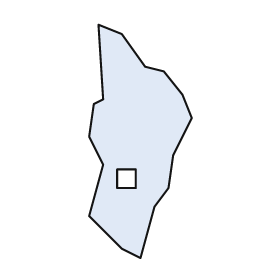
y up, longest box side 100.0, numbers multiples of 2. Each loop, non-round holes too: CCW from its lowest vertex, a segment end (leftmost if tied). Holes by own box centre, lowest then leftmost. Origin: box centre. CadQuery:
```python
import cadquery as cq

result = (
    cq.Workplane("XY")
    .moveTo(0.0, -50.0)
    .lineTo(6.0, -28.0)
    .lineTo(12.0, -20.0)
    .lineTo(14.0, -6.0)
    .lineTo(22.0, 10.0)
    .lineTo(18.0, 20.0)
    .lineTo(10.0, 30.0)
    .lineTo(2.0, 32.0)
    .lineTo(-8.0, 46.0)
    .lineTo(-18.0, 50.0)
    .lineTo(-16.0, 18.0)
    .lineTo(-20.0, 16.0)
    .lineTo(-22.0, 2.0)
    .lineTo(-16.0, -10.0)
    .lineTo(-22.0, -32.0)
    .lineTo(-8.0, -46.0)
    .close()
    .moveTo(-10.0, -20.0)
    .lineTo(-2.0, -20.0)
    .lineTo(-2.0, -12.0)
    .lineTo(-10.0, -12.0)
    .close()
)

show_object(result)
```